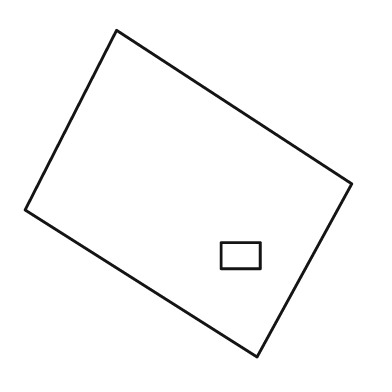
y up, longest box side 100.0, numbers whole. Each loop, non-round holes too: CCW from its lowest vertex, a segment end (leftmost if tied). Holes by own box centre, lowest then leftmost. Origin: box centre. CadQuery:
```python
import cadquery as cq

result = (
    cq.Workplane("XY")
    .moveTo(21.0, -50.0)
    .lineTo(50.0, 3.0)
    .lineTo(-22.0, 50.0)
    .lineTo(-50.0, -5.0)
    .close()
    .moveTo(10.0, -23.0)
    .lineTo(22.0, -23.0)
    .lineTo(22.0, -15.0)
    .lineTo(10.0, -15.0)
    .close()
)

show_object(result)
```